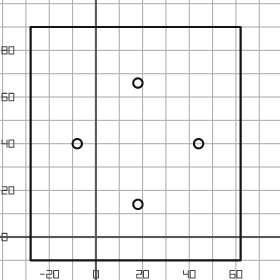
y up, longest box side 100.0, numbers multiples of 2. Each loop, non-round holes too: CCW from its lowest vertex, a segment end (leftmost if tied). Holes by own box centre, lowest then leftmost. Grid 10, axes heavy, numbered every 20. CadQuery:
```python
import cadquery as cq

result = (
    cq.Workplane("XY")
    .moveTo(-28.0, -10.0)
    .lineTo(62.0, -10.0)
    .lineTo(62.0, 90.0)
    .lineTo(-28.0, 90.0)
    .close()
    .moveTo(18.0, 14.0)
    .circle(2.0)
    .moveTo(-8.0, 40.0)
    .circle(2.0)
    .moveTo(44.0, 40.0)
    .circle(2.0)
    .moveTo(18.0, 66.0)
    .circle(2.0)
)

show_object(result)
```